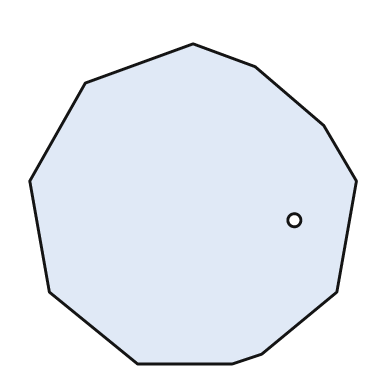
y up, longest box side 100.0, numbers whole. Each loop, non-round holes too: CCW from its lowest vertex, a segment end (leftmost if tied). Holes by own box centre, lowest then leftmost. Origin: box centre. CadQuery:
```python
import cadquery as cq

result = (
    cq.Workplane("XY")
    .moveTo(-17.0, -49.0)
    .lineTo(12.0, -49.0)
    .lineTo(21.0, -46.0)
    .lineTo(44.0, -27.0)
    .lineTo(50.0, 7.0)
    .lineTo(40.0, 24.0)
    .lineTo(19.0, 42.0)
    .lineTo(0.0, 49.0)
    .lineTo(-33.0, 37.0)
    .lineTo(-50.0, 7.0)
    .lineTo(-44.0, -27.0)
    .close()
    .moveTo(31.0, -5.0)
    .circle(2.0)
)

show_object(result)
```